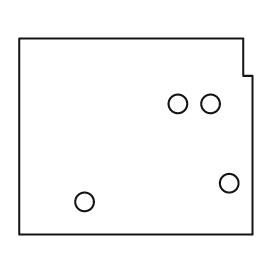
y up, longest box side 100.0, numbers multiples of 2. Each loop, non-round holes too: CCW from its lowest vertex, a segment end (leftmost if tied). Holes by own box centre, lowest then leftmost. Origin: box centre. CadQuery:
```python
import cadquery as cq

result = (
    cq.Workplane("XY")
    .moveTo(-50.0, -42.0)
    .lineTo(50.0, -42.0)
    .lineTo(50.0, 26.0)
    .lineTo(46.0, 26.0)
    .lineTo(46.0, 42.0)
    .lineTo(-50.0, 42.0)
    .close()
    .moveTo(-22.0, -28.0)
    .circle(4.0)
    .moveTo(40.0, -20.0)
    .circle(4.0)
    .moveTo(18.0, 14.0)
    .circle(4.0)
    .moveTo(32.0, 14.0)
    .circle(4.0)
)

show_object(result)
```